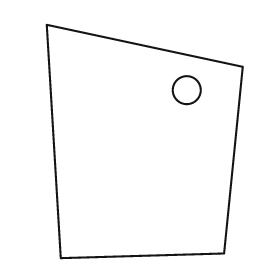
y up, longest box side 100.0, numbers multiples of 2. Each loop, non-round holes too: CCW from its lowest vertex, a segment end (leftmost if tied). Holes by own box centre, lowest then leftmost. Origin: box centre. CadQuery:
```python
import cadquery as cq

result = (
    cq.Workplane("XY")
    .moveTo(-36.0, -50.0)
    .lineTo(34.0, -48.0)
    .lineTo(42.0, 32.0)
    .lineTo(-42.0, 50.0)
    .close()
    .moveTo(18.0, 22.0)
    .circle(6.0)
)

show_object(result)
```